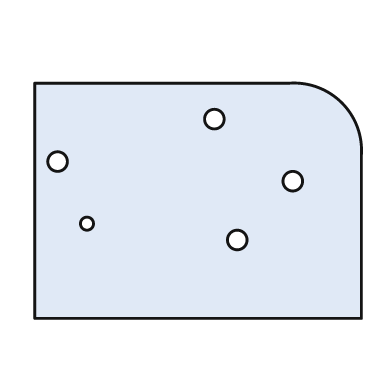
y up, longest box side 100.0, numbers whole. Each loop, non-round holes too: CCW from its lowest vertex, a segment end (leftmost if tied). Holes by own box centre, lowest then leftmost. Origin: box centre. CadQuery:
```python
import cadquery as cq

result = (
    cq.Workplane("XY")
    .moveTo(-50.0, -36.0)
    .lineTo(50.0, -36.0)
    .lineTo(50.0, 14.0)
    .threePointArc((44.0, 30.0), (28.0, 36.0))
    .lineTo(-50.0, 36.0)
    .close()
    .moveTo(12.0, -12.0)
    .circle(3.0)
    .moveTo(-34.0, -7.0)
    .circle(2.0)
    .moveTo(29.0, 6.0)
    .circle(3.0)
    .moveTo(-43.0, 12.0)
    .circle(3.0)
    .moveTo(5.0, 25.0)
    .circle(3.0)
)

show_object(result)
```